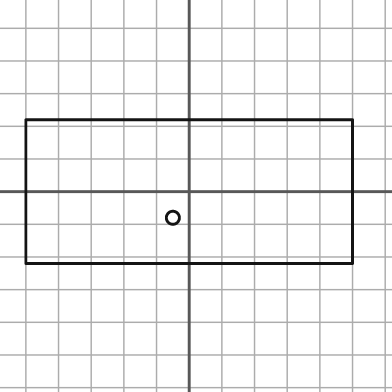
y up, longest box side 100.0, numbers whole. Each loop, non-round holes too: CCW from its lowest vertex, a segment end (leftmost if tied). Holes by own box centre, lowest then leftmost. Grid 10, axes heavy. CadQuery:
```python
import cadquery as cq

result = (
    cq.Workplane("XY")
    .moveTo(-50.0, -22.0)
    .lineTo(50.0, -22.0)
    .lineTo(50.0, 22.0)
    .lineTo(-50.0, 22.0)
    .close()
    .moveTo(-5.0, -8.0)
    .circle(2.0)
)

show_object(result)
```